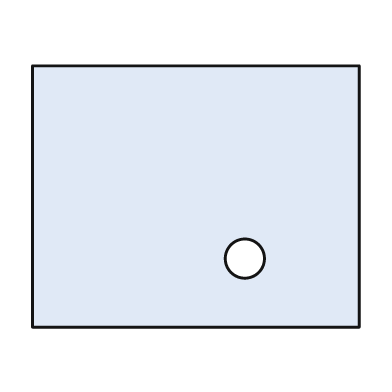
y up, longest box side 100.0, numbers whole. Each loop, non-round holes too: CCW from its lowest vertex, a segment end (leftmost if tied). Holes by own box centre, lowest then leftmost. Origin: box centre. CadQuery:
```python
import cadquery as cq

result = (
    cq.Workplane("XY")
    .moveTo(-50.0, -40.0)
    .lineTo(50.0, -40.0)
    .lineTo(50.0, 40.0)
    .lineTo(-50.0, 40.0)
    .close()
    .moveTo(15.0, -19.0)
    .circle(6.0)
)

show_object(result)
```